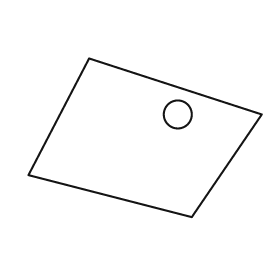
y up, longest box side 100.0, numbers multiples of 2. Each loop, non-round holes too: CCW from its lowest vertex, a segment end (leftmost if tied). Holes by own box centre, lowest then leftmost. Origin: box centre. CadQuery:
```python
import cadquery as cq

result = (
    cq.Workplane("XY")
    .moveTo(20.0, -34.0)
    .lineTo(50.0, 10.0)
    .lineTo(-24.0, 34.0)
    .lineTo(-50.0, -16.0)
    .close()
    .moveTo(14.0, 10.0)
    .circle(6.0)
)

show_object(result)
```